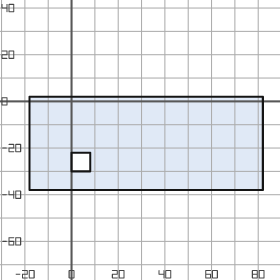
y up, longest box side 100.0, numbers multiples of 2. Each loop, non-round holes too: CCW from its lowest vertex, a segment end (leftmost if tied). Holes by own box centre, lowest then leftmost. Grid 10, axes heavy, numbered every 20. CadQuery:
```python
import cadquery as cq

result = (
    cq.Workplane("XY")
    .moveTo(-18.0, -38.0)
    .lineTo(82.0, -38.0)
    .lineTo(82.0, 2.0)
    .lineTo(-18.0, 2.0)
    .close()
    .moveTo(0.0, -30.0)
    .lineTo(8.0, -30.0)
    .lineTo(8.0, -22.0)
    .lineTo(0.0, -22.0)
    .close()
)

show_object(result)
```